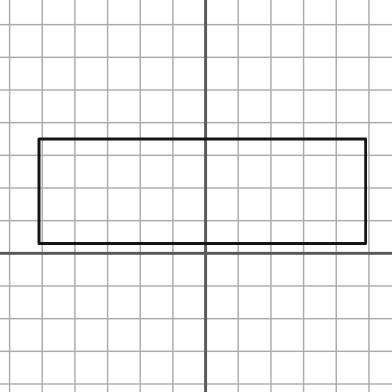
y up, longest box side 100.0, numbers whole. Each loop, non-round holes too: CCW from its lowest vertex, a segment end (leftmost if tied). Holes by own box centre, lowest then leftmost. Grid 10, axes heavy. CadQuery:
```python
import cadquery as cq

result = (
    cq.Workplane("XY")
    .moveTo(-51.0, 3.0)
    .lineTo(49.0, 3.0)
    .lineTo(49.0, 35.0)
    .lineTo(-51.0, 35.0)
    .close()
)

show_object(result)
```